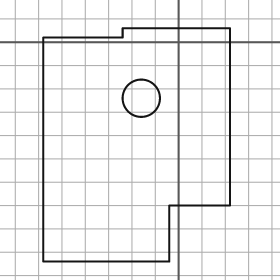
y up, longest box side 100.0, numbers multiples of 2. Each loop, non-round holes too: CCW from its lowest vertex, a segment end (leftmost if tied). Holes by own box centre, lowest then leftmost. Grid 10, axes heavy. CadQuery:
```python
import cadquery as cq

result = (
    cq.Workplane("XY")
    .moveTo(-58.0, -94.0)
    .lineTo(-4.0, -94.0)
    .lineTo(-4.0, -70.0)
    .lineTo(22.0, -70.0)
    .lineTo(22.0, 6.0)
    .lineTo(-24.0, 6.0)
    .lineTo(-24.0, 2.0)
    .lineTo(-58.0, 2.0)
    .close()
    .moveTo(-16.0, -24.0)
    .circle(8.0)
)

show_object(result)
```